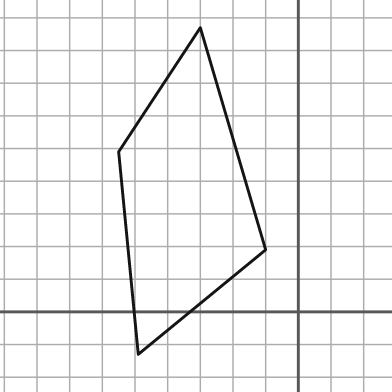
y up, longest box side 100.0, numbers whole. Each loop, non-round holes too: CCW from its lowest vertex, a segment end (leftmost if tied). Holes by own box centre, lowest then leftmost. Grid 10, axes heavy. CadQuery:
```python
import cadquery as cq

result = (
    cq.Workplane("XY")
    .moveTo(-49.0, -13.0)
    .lineTo(-10.0, 19.0)
    .lineTo(-30.0, 87.0)
    .lineTo(-55.0, 49.0)
    .close()
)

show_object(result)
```